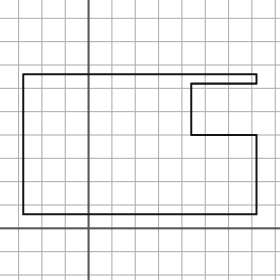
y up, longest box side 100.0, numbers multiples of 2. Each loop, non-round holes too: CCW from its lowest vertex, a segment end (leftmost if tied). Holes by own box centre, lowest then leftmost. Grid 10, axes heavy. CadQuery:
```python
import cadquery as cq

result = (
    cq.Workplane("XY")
    .moveTo(-28.0, 6.0)
    .lineTo(72.0, 6.0)
    .lineTo(72.0, 40.0)
    .lineTo(44.0, 40.0)
    .lineTo(44.0, 62.0)
    .lineTo(72.0, 62.0)
    .lineTo(72.0, 66.0)
    .lineTo(-28.0, 66.0)
    .close()
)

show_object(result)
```